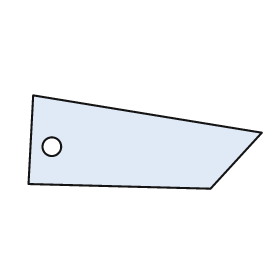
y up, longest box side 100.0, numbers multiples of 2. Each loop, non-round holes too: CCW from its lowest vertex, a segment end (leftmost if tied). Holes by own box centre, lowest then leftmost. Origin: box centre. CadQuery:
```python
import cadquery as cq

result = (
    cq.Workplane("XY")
    .moveTo(28.0, -20.0)
    .lineTo(50.0, 4.0)
    .lineTo(-48.0, 20.0)
    .lineTo(-50.0, -18.0)
    .close()
    .moveTo(-40.0, -2.0)
    .circle(4.0)
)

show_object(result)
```